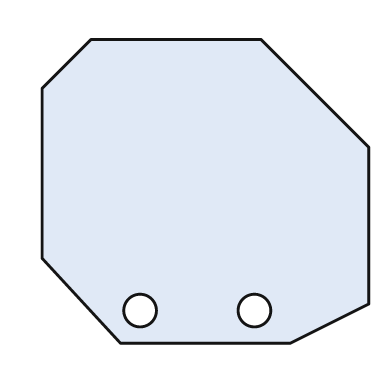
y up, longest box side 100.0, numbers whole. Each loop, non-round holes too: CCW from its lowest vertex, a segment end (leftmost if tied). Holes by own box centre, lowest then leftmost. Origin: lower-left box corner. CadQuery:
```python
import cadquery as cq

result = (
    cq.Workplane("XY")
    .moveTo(24.0, 0.0)
    .lineTo(76.0, 0.0)
    .lineTo(100.0, 12.0)
    .lineTo(100.0, 60.0)
    .lineTo(67.0, 93.0)
    .lineTo(15.0, 93.0)
    .lineTo(0.0, 78.0)
    .lineTo(0.0, 26.0)
    .close()
    .moveTo(30.0, 10.0)
    .circle(5.0)
    .moveTo(65.0, 10.0)
    .circle(5.0)
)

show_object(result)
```